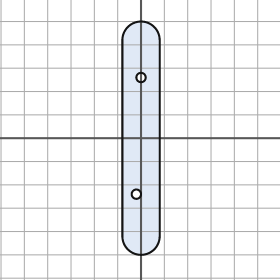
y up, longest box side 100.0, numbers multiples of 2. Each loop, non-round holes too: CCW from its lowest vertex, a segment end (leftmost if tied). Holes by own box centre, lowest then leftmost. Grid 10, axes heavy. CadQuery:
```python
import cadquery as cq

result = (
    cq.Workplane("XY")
    .moveTo(-8.0, -42.0)
    .threePointArc((0.0, -50.0), (8.0, -42.0))
    .lineTo(8.0, 42.0)
    .threePointArc((0.0, 50.0), (-8.0, 42.0))
    .close()
    .moveTo(-2.0, -24.0)
    .circle(2.0)
    .moveTo(0.0, 26.0)
    .circle(2.0)
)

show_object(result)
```